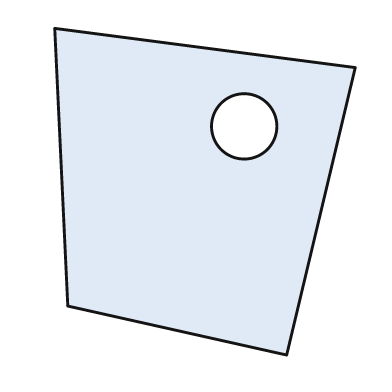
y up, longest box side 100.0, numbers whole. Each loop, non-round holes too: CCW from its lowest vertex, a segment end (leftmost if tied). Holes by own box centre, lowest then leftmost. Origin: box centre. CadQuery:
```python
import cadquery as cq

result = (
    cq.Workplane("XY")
    .moveTo(25.0, -50.0)
    .lineTo(46.0, 38.0)
    .lineTo(-46.0, 50.0)
    .lineTo(-42.0, -35.0)
    .close()
    .moveTo(12.0, 20.0)
    .circle(10.0)
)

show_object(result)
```